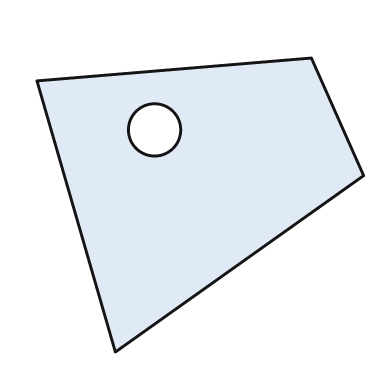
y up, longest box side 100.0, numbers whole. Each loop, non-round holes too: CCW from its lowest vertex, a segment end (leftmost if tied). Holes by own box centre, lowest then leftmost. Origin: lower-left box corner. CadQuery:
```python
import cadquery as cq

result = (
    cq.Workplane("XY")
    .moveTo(24.0, 0.0)
    .lineTo(100.0, 54.0)
    .lineTo(84.0, 90.0)
    .lineTo(0.0, 83.0)
    .close()
    .moveTo(36.0, 68.0)
    .circle(8.0)
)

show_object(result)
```